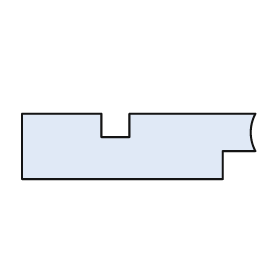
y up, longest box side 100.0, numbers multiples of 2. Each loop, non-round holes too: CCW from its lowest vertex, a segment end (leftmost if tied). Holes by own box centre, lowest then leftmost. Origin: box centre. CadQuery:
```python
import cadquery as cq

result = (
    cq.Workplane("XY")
    .moveTo(-50.0, -14.0)
    .lineTo(36.0, -14.0)
    .lineTo(36.0, -2.0)
    .lineTo(50.0, -2.0)
    .threePointArc((48.0, 6.0), (50.0, 14.0))
    .lineTo(-4.0, 14.0)
    .lineTo(-4.0, 4.0)
    .lineTo(-16.0, 4.0)
    .lineTo(-16.0, 14.0)
    .lineTo(-50.0, 14.0)
    .close()
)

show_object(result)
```